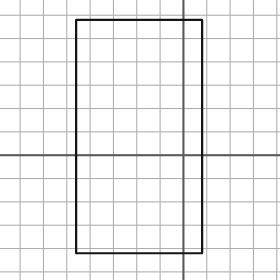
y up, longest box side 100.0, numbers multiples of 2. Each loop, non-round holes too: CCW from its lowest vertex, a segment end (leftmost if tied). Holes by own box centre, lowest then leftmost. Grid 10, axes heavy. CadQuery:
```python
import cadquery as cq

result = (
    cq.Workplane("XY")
    .moveTo(-46.0, -42.0)
    .lineTo(8.0, -42.0)
    .lineTo(8.0, 58.0)
    .lineTo(-46.0, 58.0)
    .close()
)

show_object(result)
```